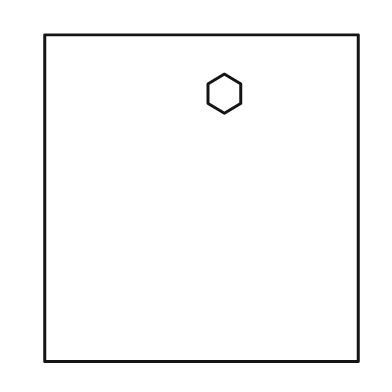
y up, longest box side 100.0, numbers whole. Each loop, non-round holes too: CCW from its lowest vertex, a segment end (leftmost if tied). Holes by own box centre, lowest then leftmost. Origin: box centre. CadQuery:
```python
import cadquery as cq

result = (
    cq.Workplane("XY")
    .moveTo(-48.0, -50.0)
    .lineTo(48.0, -50.0)
    .lineTo(48.0, 50.0)
    .lineTo(-48.0, 50.0)
    .close()
    .moveTo(7.0, 26.0)
    .lineTo(12.0, 29.0)
    .lineTo(12.0, 35.0)
    .lineTo(7.0, 38.0)
    .lineTo(2.0, 35.0)
    .lineTo(2.0, 29.0)
    .close()
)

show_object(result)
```